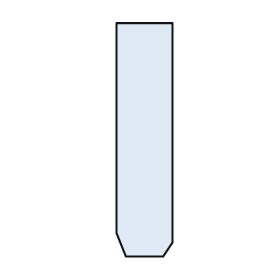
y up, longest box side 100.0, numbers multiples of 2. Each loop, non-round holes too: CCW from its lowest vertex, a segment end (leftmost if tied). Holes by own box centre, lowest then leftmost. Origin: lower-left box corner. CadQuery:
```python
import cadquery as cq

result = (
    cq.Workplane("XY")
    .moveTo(4.0, 0.0)
    .lineTo(20.0, 0.0)
    .lineTo(24.0, 6.0)
    .lineTo(24.0, 100.0)
    .lineTo(0.0, 100.0)
    .lineTo(0.0, 10.0)
    .close()
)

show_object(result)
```